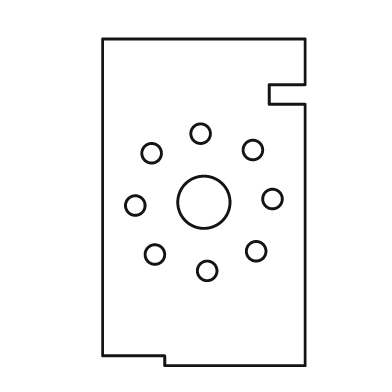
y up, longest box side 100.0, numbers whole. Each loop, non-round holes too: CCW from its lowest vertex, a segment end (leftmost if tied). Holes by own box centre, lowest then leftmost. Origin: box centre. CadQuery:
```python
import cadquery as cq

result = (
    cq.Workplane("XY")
    .moveTo(-12.0, -50.0)
    .lineTo(31.0, -50.0)
    .lineTo(31.0, 30.0)
    .lineTo(20.0, 30.0)
    .lineTo(20.0, 36.0)
    .lineTo(31.0, 36.0)
    .lineTo(31.0, 50.0)
    .lineTo(-31.0, 50.0)
    .lineTo(-31.0, -47.0)
    .lineTo(-12.0, -47.0)
    .close()
    .moveTo(1.0, -21.0)
    .circle(3.0)
    .moveTo(-15.0, -16.0)
    .circle(3.0)
    .moveTo(16.0, -15.0)
    .circle(3.0)
    .moveTo(-21.0, -1.0)
    .circle(3.0)
    .moveTo(0.0, 0.0)
    .circle(8.0)
    .moveTo(21.0, 1.0)
    .circle(3.0)
    .moveTo(-16.0, 15.0)
    .circle(3.0)
    .moveTo(15.0, 16.0)
    .circle(3.0)
    .moveTo(-1.0, 21.0)
    .circle(3.0)
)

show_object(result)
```